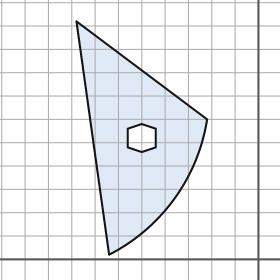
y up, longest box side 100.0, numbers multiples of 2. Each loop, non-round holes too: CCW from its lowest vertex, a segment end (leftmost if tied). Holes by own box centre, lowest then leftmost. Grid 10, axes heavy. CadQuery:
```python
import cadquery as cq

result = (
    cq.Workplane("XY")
    .moveTo(-64.0, 2.0)
    .threePointArc((-36.0, 26.0), (-22.0, 60.0))
    .lineTo(-78.0, 102.0)
    .close()
    .moveTo(-50.0, 46.0)
    .lineTo(-44.0, 48.0)
    .lineTo(-44.0, 56.0)
    .lineTo(-50.0, 58.0)
    .lineTo(-56.0, 56.0)
    .lineTo(-56.0, 48.0)
    .close()
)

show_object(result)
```